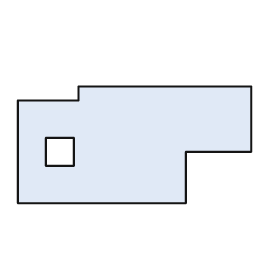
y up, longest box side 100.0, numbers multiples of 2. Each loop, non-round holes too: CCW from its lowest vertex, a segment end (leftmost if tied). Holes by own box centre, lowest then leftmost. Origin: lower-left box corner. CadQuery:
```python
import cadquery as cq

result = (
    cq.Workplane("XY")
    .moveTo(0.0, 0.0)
    .lineTo(72.0, 0.0)
    .lineTo(72.0, 22.0)
    .lineTo(100.0, 22.0)
    .lineTo(100.0, 50.0)
    .lineTo(26.0, 50.0)
    .lineTo(26.0, 44.0)
    .lineTo(0.0, 44.0)
    .close()
    .moveTo(12.0, 16.0)
    .lineTo(24.0, 16.0)
    .lineTo(24.0, 28.0)
    .lineTo(12.0, 28.0)
    .close()
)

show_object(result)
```